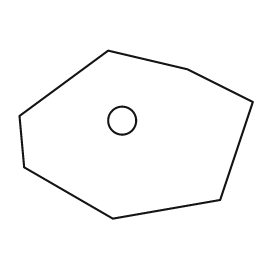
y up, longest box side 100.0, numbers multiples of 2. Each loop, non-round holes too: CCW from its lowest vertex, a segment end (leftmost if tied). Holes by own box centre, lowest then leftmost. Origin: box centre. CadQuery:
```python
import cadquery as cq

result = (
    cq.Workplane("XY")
    .moveTo(-10.0, -36.0)
    .lineTo(36.0, -28.0)
    .lineTo(50.0, 14.0)
    .lineTo(22.0, 28.0)
    .lineTo(-12.0, 36.0)
    .lineTo(-50.0, 8.0)
    .lineTo(-48.0, -14.0)
    .close()
    .moveTo(-6.0, 6.0)
    .circle(6.0)
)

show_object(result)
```